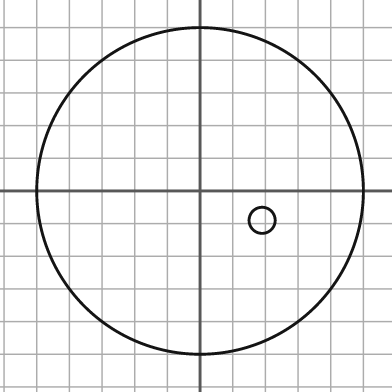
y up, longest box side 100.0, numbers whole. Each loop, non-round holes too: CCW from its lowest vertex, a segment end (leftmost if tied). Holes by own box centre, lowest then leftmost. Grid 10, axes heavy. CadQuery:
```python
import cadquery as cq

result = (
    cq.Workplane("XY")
    .moveTo(0.0, 0.0)
    .circle(50.0)
    .moveTo(19.0, -9.0)
    .circle(4.0)
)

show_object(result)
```